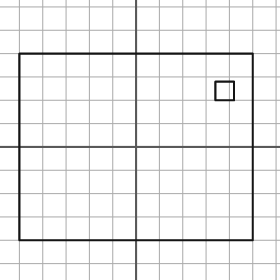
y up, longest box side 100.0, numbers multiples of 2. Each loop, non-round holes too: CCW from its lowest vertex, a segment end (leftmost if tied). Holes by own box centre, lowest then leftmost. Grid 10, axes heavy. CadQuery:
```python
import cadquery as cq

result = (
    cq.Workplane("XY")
    .moveTo(-50.0, -40.0)
    .lineTo(50.0, -40.0)
    .lineTo(50.0, 40.0)
    .lineTo(-50.0, 40.0)
    .close()
    .moveTo(34.0, 20.0)
    .lineTo(42.0, 20.0)
    .lineTo(42.0, 28.0)
    .lineTo(34.0, 28.0)
    .close()
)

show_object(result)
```